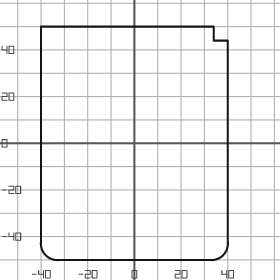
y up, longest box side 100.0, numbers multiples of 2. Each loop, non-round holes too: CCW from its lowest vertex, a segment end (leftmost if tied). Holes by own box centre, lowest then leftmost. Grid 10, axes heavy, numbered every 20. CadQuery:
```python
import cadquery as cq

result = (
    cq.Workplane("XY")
    .moveTo(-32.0, -50.0)
    .lineTo(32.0, -50.0)
    .threePointArc((38.0, -48.0), (40.0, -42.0))
    .lineTo(40.0, 44.0)
    .lineTo(34.0, 44.0)
    .lineTo(34.0, 50.0)
    .lineTo(-40.0, 50.0)
    .lineTo(-40.0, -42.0)
    .threePointArc((-38.0, -48.0), (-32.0, -50.0))
    .close()
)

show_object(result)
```